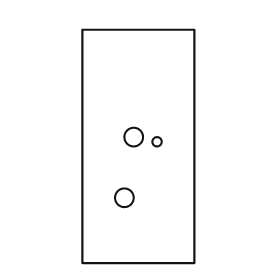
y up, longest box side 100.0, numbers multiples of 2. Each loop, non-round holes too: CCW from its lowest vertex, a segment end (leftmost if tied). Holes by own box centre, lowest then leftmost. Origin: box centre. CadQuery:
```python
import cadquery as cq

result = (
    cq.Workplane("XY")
    .moveTo(-24.0, -50.0)
    .lineTo(24.0, -50.0)
    .lineTo(24.0, 50.0)
    .lineTo(-24.0, 50.0)
    .close()
    .moveTo(-6.0, -22.0)
    .circle(4.0)
    .moveTo(8.0, 2.0)
    .circle(2.0)
    .moveTo(-2.0, 4.0)
    .circle(4.0)
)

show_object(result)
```